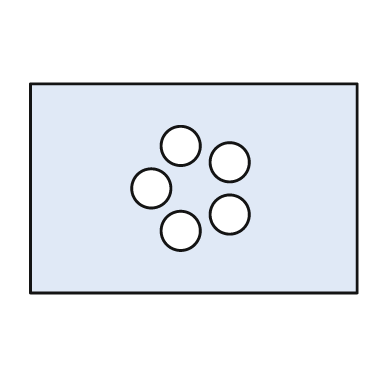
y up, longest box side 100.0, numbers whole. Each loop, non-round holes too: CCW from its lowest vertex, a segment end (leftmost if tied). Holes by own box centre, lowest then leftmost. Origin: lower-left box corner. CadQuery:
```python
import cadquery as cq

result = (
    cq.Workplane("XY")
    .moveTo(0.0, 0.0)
    .lineTo(100.0, 0.0)
    .lineTo(100.0, 64.0)
    .lineTo(0.0, 64.0)
    .close()
    .moveTo(46.0, 19.0)
    .circle(6.0)
    .moveTo(61.0, 24.0)
    .circle(6.0)
    .moveTo(37.0, 32.0)
    .circle(6.0)
    .moveTo(61.0, 40.0)
    .circle(6.0)
    .moveTo(46.0, 45.0)
    .circle(6.0)
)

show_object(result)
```